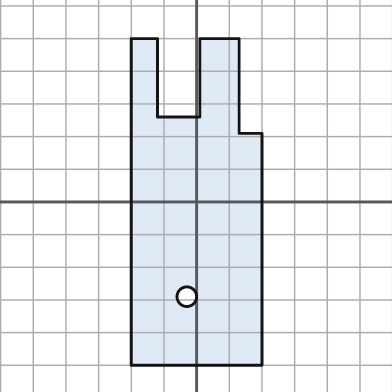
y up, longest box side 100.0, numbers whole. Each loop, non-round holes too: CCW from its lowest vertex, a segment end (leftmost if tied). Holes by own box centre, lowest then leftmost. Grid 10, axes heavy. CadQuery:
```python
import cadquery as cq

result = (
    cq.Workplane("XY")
    .moveTo(-20.0, -50.0)
    .lineTo(20.0, -50.0)
    .lineTo(20.0, 21.0)
    .lineTo(13.0, 21.0)
    .lineTo(13.0, 50.0)
    .lineTo(1.0, 50.0)
    .lineTo(1.0, 26.0)
    .lineTo(-12.0, 26.0)
    .lineTo(-12.0, 50.0)
    .lineTo(-20.0, 50.0)
    .close()
    .moveTo(-3.0, -29.0)
    .circle(3.0)
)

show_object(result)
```